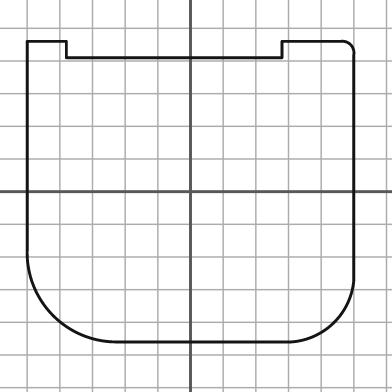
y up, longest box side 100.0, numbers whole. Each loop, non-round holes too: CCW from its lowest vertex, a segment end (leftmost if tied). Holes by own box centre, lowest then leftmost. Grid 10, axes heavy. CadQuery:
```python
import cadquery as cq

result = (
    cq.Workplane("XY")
    .moveTo(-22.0, -46.0)
    .lineTo(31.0, -46.0)
    .threePointArc((44.0, -40.0), (50.0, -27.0))
    .lineTo(50.0, 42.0)
    .threePointArc((49.0, 45.0), (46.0, 46.0))
    .lineTo(28.0, 46.0)
    .lineTo(28.0, 41.0)
    .lineTo(-38.0, 41.0)
    .lineTo(-38.0, 46.0)
    .lineTo(-50.0, 46.0)
    .lineTo(-50.0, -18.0)
    .threePointArc((-42.0, -38.0), (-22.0, -46.0))
    .close()
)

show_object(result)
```